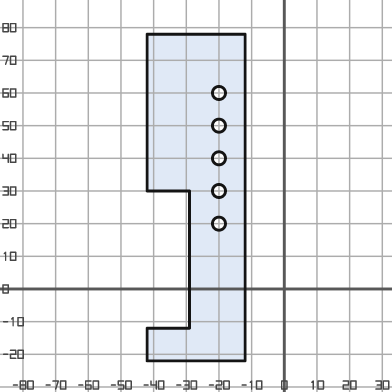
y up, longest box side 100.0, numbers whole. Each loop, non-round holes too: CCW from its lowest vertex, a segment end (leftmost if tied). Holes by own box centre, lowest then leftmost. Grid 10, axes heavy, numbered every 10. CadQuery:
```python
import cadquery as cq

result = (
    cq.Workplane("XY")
    .moveTo(-42.0, -22.0)
    .lineTo(-12.0, -22.0)
    .lineTo(-12.0, 78.0)
    .lineTo(-42.0, 78.0)
    .lineTo(-42.0, 30.0)
    .lineTo(-29.0, 30.0)
    .lineTo(-29.0, -12.0)
    .lineTo(-42.0, -12.0)
    .close()
    .moveTo(-20.0, 20.0)
    .circle(2.0)
    .moveTo(-20.0, 30.0)
    .circle(2.0)
    .moveTo(-20.0, 40.0)
    .circle(2.0)
    .moveTo(-20.0, 50.0)
    .circle(2.0)
    .moveTo(-20.0, 60.0)
    .circle(2.0)
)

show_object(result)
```